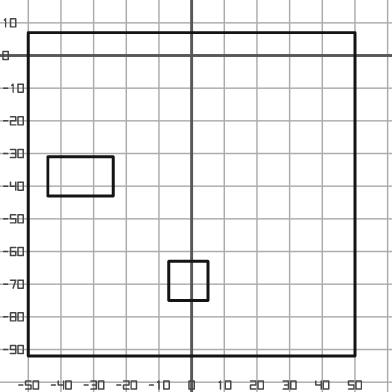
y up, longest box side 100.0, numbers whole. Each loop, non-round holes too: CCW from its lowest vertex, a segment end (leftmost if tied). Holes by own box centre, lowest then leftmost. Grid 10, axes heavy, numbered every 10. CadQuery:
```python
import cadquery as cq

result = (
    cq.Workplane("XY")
    .moveTo(-50.0, -92.0)
    .lineTo(50.0, -92.0)
    .lineTo(50.0, 7.0)
    .lineTo(-50.0, 7.0)
    .close()
    .moveTo(-7.0, -75.0)
    .lineTo(5.0, -75.0)
    .lineTo(5.0, -63.0)
    .lineTo(-7.0, -63.0)
    .close()
    .moveTo(-44.0, -43.0)
    .lineTo(-24.0, -43.0)
    .lineTo(-24.0, -31.0)
    .lineTo(-44.0, -31.0)
    .close()
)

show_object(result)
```